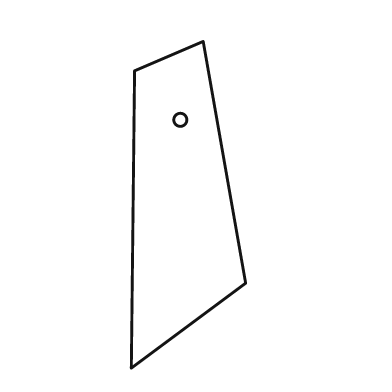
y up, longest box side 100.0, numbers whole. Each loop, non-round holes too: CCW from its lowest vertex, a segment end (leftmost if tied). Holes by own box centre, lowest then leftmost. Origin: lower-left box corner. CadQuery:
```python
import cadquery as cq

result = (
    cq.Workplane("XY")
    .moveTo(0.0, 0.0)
    .lineTo(35.0, 26.0)
    .lineTo(22.0, 100.0)
    .lineTo(1.0, 91.0)
    .close()
    .moveTo(15.0, 76.0)
    .circle(2.0)
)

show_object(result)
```